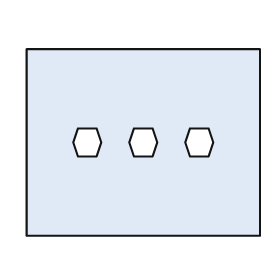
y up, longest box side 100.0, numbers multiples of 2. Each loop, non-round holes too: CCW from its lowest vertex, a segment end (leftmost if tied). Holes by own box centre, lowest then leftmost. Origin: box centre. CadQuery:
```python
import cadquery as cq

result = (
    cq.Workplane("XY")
    .moveTo(-50.0, -40.0)
    .lineTo(50.0, -40.0)
    .lineTo(50.0, 40.0)
    .lineTo(-50.0, 40.0)
    .close()
    .moveTo(-28.0, -6.0)
    .lineTo(-20.0, -6.0)
    .lineTo(-18.0, 0.0)
    .lineTo(-20.0, 6.0)
    .lineTo(-28.0, 6.0)
    .lineTo(-30.0, 0.0)
    .close()
    .moveTo(-4.0, -6.0)
    .lineTo(4.0, -6.0)
    .lineTo(6.0, 0.0)
    .lineTo(4.0, 6.0)
    .lineTo(-4.0, 6.0)
    .lineTo(-6.0, 0.0)
    .close()
    .moveTo(20.0, -6.0)
    .lineTo(28.0, -6.0)
    .lineTo(30.0, 0.0)
    .lineTo(28.0, 6.0)
    .lineTo(20.0, 6.0)
    .lineTo(18.0, 0.0)
    .close()
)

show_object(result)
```